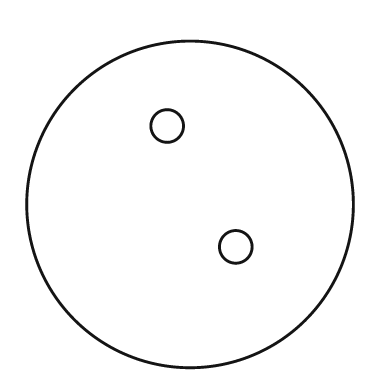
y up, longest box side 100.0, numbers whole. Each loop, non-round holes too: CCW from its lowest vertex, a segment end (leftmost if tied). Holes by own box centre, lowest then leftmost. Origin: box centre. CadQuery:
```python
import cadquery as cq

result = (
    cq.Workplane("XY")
    .moveTo(0.0, 0.0)
    .circle(50.0)
    .moveTo(14.0, -13.0)
    .circle(5.0)
    .moveTo(-7.0, 24.0)
    .circle(5.0)
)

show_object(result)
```